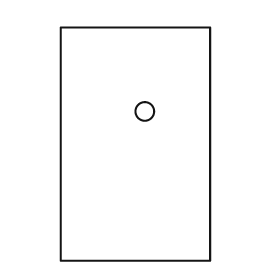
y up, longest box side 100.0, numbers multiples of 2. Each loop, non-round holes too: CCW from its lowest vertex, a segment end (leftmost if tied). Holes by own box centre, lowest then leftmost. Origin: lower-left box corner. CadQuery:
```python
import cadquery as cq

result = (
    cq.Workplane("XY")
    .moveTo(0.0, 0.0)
    .lineTo(64.0, 0.0)
    .lineTo(64.0, 100.0)
    .lineTo(0.0, 100.0)
    .close()
    .moveTo(36.0, 64.0)
    .circle(4.0)
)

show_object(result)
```